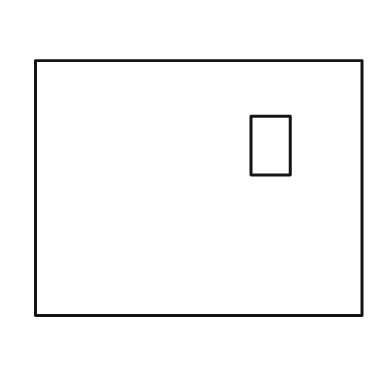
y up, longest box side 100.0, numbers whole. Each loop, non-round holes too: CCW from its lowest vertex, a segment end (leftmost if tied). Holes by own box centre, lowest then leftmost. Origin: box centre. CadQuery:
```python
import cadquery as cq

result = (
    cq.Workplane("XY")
    .moveTo(-50.0, -39.0)
    .lineTo(50.0, -39.0)
    .lineTo(50.0, 39.0)
    .lineTo(-50.0, 39.0)
    .close()
    .moveTo(16.0, 4.0)
    .lineTo(28.0, 4.0)
    .lineTo(28.0, 22.0)
    .lineTo(16.0, 22.0)
    .close()
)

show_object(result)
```